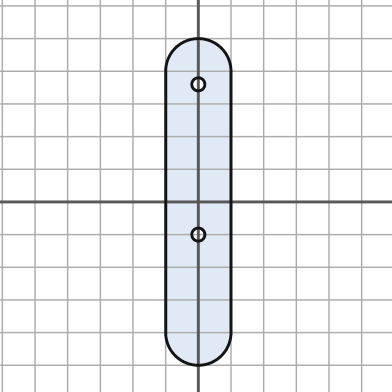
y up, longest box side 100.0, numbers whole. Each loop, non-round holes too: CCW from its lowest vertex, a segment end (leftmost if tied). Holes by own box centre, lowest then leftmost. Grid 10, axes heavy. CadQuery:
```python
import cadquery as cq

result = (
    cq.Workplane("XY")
    .moveTo(-10.0, -40.0)
    .threePointArc((0.0, -50.0), (10.0, -40.0))
    .lineTo(10.0, 40.0)
    .threePointArc((0.0, 50.0), (-10.0, 40.0))
    .close()
    .moveTo(0.0, -10.0)
    .circle(2.0)
    .moveTo(0.0, 36.0)
    .circle(2.0)
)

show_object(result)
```